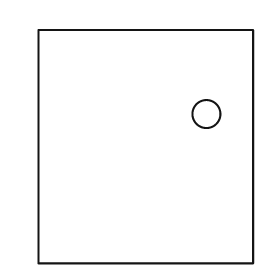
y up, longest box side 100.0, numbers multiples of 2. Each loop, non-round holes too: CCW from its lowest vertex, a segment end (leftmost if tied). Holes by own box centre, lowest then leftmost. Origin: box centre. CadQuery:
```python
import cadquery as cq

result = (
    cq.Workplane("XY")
    .moveTo(-46.0, -50.0)
    .lineTo(46.0, -50.0)
    .lineTo(46.0, 50.0)
    .lineTo(-46.0, 50.0)
    .close()
    .moveTo(26.0, 14.0)
    .circle(6.0)
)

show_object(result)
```